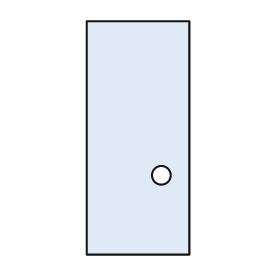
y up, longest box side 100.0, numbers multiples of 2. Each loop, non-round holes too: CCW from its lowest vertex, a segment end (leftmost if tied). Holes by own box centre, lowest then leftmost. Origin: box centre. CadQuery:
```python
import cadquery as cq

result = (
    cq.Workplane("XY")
    .moveTo(-22.0, -50.0)
    .lineTo(22.0, -50.0)
    .lineTo(22.0, 50.0)
    .lineTo(-22.0, 50.0)
    .close()
    .moveTo(10.0, -16.0)
    .circle(4.0)
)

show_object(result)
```